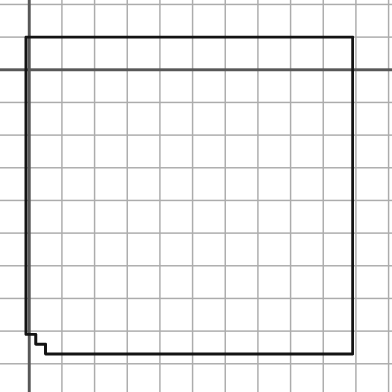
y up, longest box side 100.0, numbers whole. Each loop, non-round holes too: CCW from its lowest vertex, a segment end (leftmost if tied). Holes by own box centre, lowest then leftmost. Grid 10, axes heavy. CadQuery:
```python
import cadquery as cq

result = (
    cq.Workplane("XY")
    .moveTo(5.0, -87.0)
    .lineTo(99.0, -87.0)
    .lineTo(99.0, 10.0)
    .lineTo(-1.0, 10.0)
    .lineTo(-1.0, -81.0)
    .lineTo(2.0, -81.0)
    .lineTo(2.0, -84.0)
    .lineTo(5.0, -84.0)
    .close()
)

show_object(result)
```